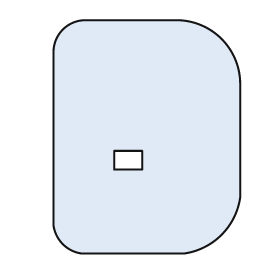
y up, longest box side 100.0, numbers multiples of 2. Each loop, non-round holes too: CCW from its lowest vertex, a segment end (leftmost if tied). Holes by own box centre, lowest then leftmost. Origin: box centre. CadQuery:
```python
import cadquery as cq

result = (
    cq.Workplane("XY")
    .moveTo(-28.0, -50.0)
    .lineTo(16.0, -50.0)
    .threePointArc((32.0, -42.0), (40.0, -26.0))
    .lineTo(40.0, 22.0)
    .threePointArc((32.0, 42.0), (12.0, 50.0))
    .lineTo(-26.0, 50.0)
    .threePointArc((-36.0, 46.0), (-40.0, 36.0))
    .lineTo(-40.0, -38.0)
    .threePointArc((-36.0, -46.0), (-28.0, -50.0))
    .close()
    .moveTo(-14.0, -14.0)
    .lineTo(-2.0, -14.0)
    .lineTo(-2.0, -6.0)
    .lineTo(-14.0, -6.0)
    .close()
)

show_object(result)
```